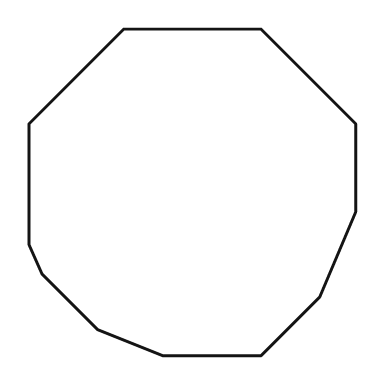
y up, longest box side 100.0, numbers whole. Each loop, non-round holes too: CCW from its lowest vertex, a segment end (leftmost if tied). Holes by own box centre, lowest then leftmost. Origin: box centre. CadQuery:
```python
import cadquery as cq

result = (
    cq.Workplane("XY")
    .moveTo(-9.0, -50.0)
    .lineTo(21.0, -50.0)
    .lineTo(39.0, -32.0)
    .lineTo(50.0, -6.0)
    .lineTo(50.0, 21.0)
    .lineTo(21.0, 50.0)
    .lineTo(-21.0, 50.0)
    .lineTo(-50.0, 21.0)
    .lineTo(-50.0, -16.0)
    .lineTo(-46.0, -25.0)
    .lineTo(-29.0, -42.0)
    .close()
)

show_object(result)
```